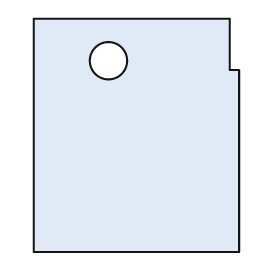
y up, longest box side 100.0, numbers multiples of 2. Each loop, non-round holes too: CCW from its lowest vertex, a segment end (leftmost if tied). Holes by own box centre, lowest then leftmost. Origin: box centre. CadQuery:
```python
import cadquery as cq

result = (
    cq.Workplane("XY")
    .moveTo(-44.0, -50.0)
    .lineTo(44.0, -50.0)
    .lineTo(44.0, 28.0)
    .lineTo(40.0, 28.0)
    .lineTo(40.0, 50.0)
    .lineTo(-44.0, 50.0)
    .close()
    .moveTo(-12.0, 32.0)
    .circle(8.0)
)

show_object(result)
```